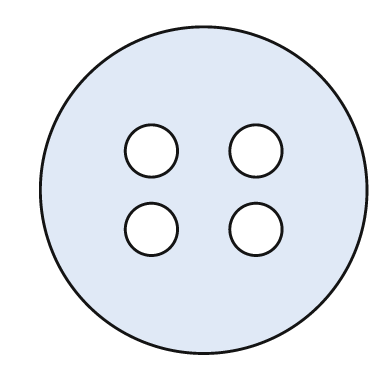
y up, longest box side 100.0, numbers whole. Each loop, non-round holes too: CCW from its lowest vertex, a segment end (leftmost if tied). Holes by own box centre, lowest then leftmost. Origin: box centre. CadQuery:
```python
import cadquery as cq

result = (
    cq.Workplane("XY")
    .moveTo(0.0, 0.0)
    .circle(50.0)
    .moveTo(-16.0, -12.0)
    .circle(8.0)
    .moveTo(16.0, -12.0)
    .circle(8.0)
    .moveTo(-16.0, 12.0)
    .circle(8.0)
    .moveTo(16.0, 12.0)
    .circle(8.0)
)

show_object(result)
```